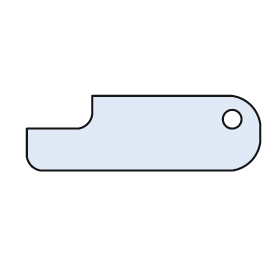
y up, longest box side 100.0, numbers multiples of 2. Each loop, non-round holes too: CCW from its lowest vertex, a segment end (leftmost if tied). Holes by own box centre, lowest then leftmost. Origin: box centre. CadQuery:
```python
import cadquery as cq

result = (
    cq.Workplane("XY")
    .moveTo(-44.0, -16.0)
    .lineTo(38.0, -16.0)
    .threePointArc((46.0, -12.0), (50.0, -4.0))
    .lineTo(50.0, 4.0)
    .threePointArc((46.0, 12.0), (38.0, 16.0))
    .lineTo(-22.0, 16.0)
    .lineTo(-22.0, 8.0)
    .threePointArc((-24.0, 4.0), (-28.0, 2.0))
    .lineTo(-50.0, 2.0)
    .lineTo(-50.0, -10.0)
    .threePointArc((-48.0, -14.0), (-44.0, -16.0))
    .close()
    .moveTo(38.0, 6.0)
    .circle(4.0)
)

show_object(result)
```